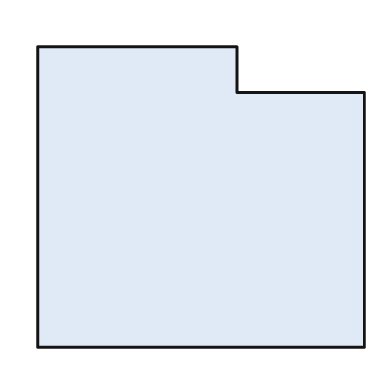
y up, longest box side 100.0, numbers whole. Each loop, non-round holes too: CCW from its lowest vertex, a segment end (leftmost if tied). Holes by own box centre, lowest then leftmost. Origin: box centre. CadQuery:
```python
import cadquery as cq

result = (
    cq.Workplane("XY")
    .moveTo(-50.0, -46.0)
    .lineTo(50.0, -46.0)
    .lineTo(50.0, 32.0)
    .lineTo(11.0, 32.0)
    .lineTo(11.0, 46.0)
    .lineTo(-50.0, 46.0)
    .close()
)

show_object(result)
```